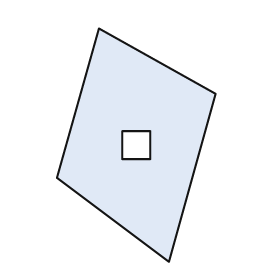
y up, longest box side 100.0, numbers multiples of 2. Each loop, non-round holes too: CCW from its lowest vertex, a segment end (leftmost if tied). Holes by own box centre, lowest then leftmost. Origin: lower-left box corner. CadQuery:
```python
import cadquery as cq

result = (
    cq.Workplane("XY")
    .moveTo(48.0, 0.0)
    .lineTo(68.0, 72.0)
    .lineTo(18.0, 100.0)
    .lineTo(0.0, 36.0)
    .close()
    .moveTo(28.0, 44.0)
    .lineTo(40.0, 44.0)
    .lineTo(40.0, 56.0)
    .lineTo(28.0, 56.0)
    .close()
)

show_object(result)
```